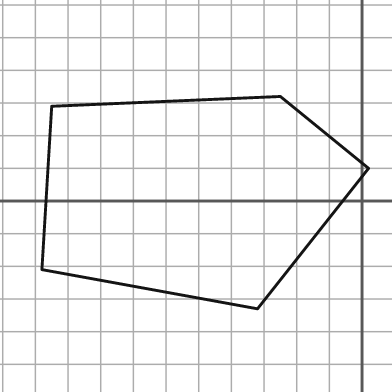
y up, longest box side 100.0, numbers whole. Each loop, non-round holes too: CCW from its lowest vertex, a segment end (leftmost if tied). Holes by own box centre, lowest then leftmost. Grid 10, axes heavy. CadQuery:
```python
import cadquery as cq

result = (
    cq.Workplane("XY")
    .moveTo(-32.0, -33.0)
    .lineTo(2.0, 10.0)
    .lineTo(-25.0, 32.0)
    .lineTo(-95.0, 29.0)
    .lineTo(-98.0, -21.0)
    .close()
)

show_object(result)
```